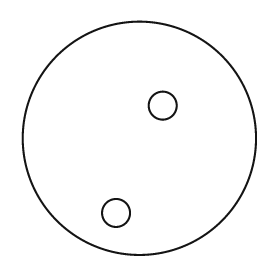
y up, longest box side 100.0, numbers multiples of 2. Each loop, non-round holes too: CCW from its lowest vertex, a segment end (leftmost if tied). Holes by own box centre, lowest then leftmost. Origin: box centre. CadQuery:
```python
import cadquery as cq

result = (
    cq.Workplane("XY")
    .moveTo(0.0, 0.0)
    .circle(50.0)
    .moveTo(-10.0, -32.0)
    .circle(6.0)
    .moveTo(10.0, 14.0)
    .circle(6.0)
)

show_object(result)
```